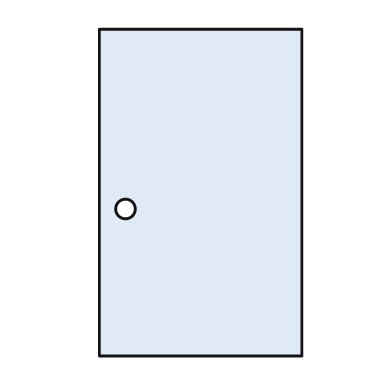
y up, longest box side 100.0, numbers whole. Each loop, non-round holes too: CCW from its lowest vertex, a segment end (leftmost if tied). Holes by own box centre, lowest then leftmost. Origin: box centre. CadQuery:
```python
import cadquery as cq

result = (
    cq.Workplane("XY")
    .moveTo(-31.0, -50.0)
    .lineTo(31.0, -50.0)
    .lineTo(31.0, 50.0)
    .lineTo(-31.0, 50.0)
    .close()
    .moveTo(-23.0, -5.0)
    .circle(3.0)
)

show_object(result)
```